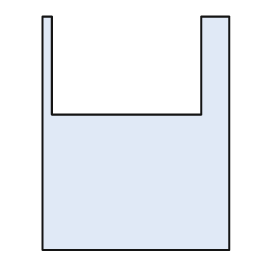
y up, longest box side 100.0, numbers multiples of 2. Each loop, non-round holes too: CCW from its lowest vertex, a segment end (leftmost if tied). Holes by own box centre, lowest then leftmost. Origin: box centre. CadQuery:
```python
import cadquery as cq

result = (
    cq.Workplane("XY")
    .moveTo(-40.0, -50.0)
    .lineTo(40.0, -50.0)
    .lineTo(40.0, 50.0)
    .lineTo(28.0, 50.0)
    .lineTo(28.0, 8.0)
    .lineTo(-36.0, 8.0)
    .lineTo(-36.0, 50.0)
    .lineTo(-40.0, 50.0)
    .close()
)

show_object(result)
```